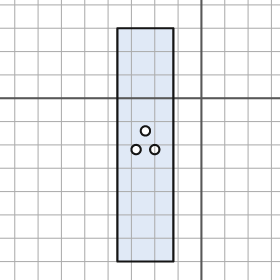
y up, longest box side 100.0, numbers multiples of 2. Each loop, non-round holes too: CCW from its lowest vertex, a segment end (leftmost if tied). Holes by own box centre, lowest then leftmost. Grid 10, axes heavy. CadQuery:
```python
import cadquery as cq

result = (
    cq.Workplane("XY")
    .moveTo(-36.0, -70.0)
    .lineTo(-12.0, -70.0)
    .lineTo(-12.0, 30.0)
    .lineTo(-36.0, 30.0)
    .close()
    .moveTo(-28.0, -22.0)
    .circle(2.0)
    .moveTo(-20.0, -22.0)
    .circle(2.0)
    .moveTo(-24.0, -14.0)
    .circle(2.0)
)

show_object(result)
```